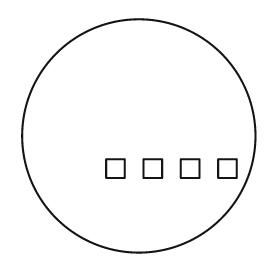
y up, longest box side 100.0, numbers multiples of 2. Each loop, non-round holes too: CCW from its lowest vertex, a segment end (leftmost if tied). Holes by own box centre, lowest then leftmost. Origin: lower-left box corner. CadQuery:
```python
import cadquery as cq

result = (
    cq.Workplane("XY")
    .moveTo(50.0, 50.0)
    .circle(50.0)
    .moveTo(36.0, 32.0)
    .lineTo(44.0, 32.0)
    .lineTo(44.0, 40.0)
    .lineTo(36.0, 40.0)
    .close()
    .moveTo(52.0, 32.0)
    .lineTo(60.0, 32.0)
    .lineTo(60.0, 40.0)
    .lineTo(52.0, 40.0)
    .close()
    .moveTo(68.0, 32.0)
    .lineTo(76.0, 32.0)
    .lineTo(76.0, 40.0)
    .lineTo(68.0, 40.0)
    .close()
    .moveTo(84.0, 32.0)
    .lineTo(92.0, 32.0)
    .lineTo(92.0, 40.0)
    .lineTo(84.0, 40.0)
    .close()
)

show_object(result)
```